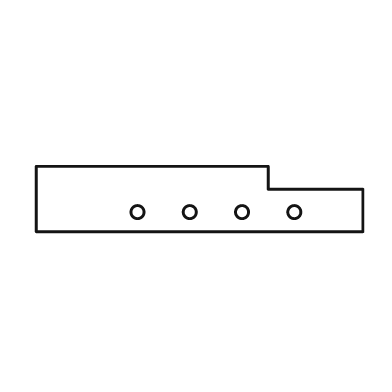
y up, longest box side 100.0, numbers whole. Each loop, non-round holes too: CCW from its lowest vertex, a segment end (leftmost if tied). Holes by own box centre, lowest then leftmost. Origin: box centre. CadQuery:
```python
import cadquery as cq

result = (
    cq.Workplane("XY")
    .moveTo(-50.0, -10.0)
    .lineTo(50.0, -10.0)
    .lineTo(50.0, 3.0)
    .lineTo(21.0, 3.0)
    .lineTo(21.0, 10.0)
    .lineTo(-50.0, 10.0)
    .close()
    .moveTo(-19.0, -4.0)
    .circle(2.0)
    .moveTo(-3.0, -4.0)
    .circle(2.0)
    .moveTo(13.0, -4.0)
    .circle(2.0)
    .moveTo(29.0, -4.0)
    .circle(2.0)
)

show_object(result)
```